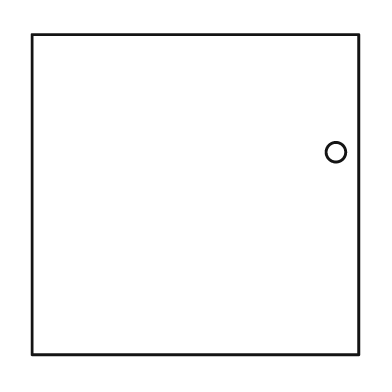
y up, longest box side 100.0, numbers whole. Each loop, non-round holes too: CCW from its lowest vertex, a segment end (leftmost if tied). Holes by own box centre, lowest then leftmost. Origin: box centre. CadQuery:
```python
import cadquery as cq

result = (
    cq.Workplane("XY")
    .moveTo(-50.0, -49.0)
    .lineTo(50.0, -49.0)
    .lineTo(50.0, 49.0)
    .lineTo(-50.0, 49.0)
    .close()
    .moveTo(43.0, 13.0)
    .circle(3.0)
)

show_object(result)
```